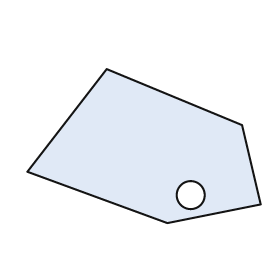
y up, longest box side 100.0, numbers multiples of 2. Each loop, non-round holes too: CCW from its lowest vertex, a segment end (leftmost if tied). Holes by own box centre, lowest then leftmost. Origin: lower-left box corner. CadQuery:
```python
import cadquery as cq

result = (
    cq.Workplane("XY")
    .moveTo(60.0, 0.0)
    .lineTo(100.0, 8.0)
    .lineTo(92.0, 42.0)
    .lineTo(34.0, 66.0)
    .lineTo(0.0, 22.0)
    .close()
    .moveTo(70.0, 12.0)
    .circle(6.0)
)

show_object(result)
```